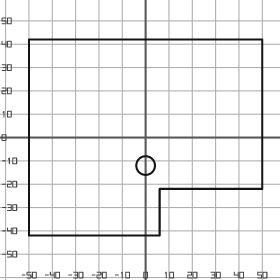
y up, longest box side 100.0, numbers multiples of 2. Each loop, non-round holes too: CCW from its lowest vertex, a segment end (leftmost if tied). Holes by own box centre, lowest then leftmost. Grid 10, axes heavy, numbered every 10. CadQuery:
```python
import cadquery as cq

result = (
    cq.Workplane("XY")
    .moveTo(-50.0, -42.0)
    .lineTo(6.0, -42.0)
    .lineTo(6.0, -22.0)
    .lineTo(50.0, -22.0)
    .lineTo(50.0, 42.0)
    .lineTo(-50.0, 42.0)
    .close()
    .moveTo(0.0, -12.0)
    .circle(4.0)
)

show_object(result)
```